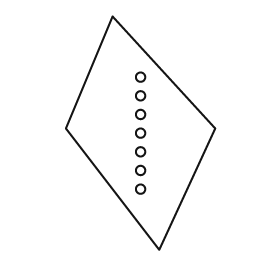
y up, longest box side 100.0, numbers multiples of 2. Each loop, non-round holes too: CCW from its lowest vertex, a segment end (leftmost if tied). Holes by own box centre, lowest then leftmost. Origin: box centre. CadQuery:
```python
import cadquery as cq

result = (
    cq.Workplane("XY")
    .moveTo(8.0, -50.0)
    .lineTo(32.0, 2.0)
    .lineTo(-12.0, 50.0)
    .lineTo(-32.0, 2.0)
    .close()
    .moveTo(0.0, -24.0)
    .circle(2.0)
    .moveTo(0.0, -16.0)
    .circle(2.0)
    .moveTo(0.0, -8.0)
    .circle(2.0)
    .moveTo(0.0, 0.0)
    .circle(2.0)
    .moveTo(0.0, 8.0)
    .circle(2.0)
    .moveTo(0.0, 16.0)
    .circle(2.0)
    .moveTo(0.0, 24.0)
    .circle(2.0)
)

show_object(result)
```